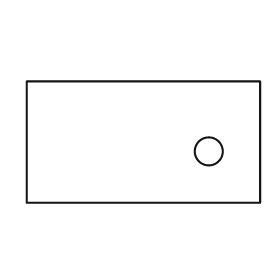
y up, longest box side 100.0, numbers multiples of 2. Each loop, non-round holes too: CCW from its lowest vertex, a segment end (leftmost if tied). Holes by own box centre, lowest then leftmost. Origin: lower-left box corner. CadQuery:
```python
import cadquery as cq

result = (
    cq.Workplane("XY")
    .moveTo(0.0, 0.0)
    .lineTo(100.0, 0.0)
    .lineTo(100.0, 52.0)
    .lineTo(0.0, 52.0)
    .close()
    .moveTo(78.0, 22.0)
    .circle(6.0)
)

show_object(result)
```